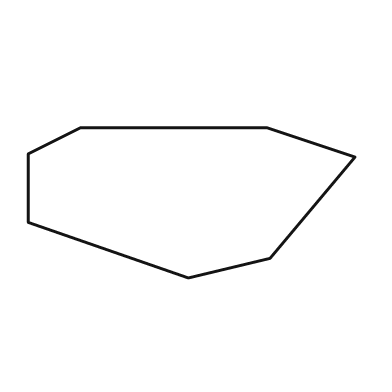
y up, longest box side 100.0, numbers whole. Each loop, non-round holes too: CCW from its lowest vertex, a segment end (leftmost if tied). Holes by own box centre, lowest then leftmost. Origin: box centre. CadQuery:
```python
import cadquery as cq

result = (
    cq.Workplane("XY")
    .moveTo(-1.0, -23.0)
    .lineTo(24.0, -17.0)
    .lineTo(50.0, 14.0)
    .lineTo(23.0, 23.0)
    .lineTo(-34.0, 23.0)
    .lineTo(-50.0, 15.0)
    .lineTo(-50.0, -6.0)
    .close()
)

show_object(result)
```